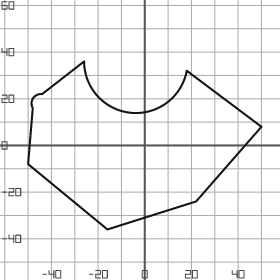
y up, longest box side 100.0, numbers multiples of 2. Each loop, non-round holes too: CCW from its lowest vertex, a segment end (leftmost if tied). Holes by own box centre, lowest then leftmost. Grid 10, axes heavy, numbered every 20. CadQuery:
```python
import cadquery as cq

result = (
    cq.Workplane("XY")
    .moveTo(-16.0, -36.0)
    .lineTo(22.0, -24.0)
    .lineTo(50.0, 8.0)
    .lineTo(18.0, 32.0)
    .threePointArc((-6.0, 14.0), (-26.0, 36.0))
    .lineTo(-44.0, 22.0)
    .threePointArc((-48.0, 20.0), (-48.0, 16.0))
    .lineTo(-50.0, -8.0)
    .close()
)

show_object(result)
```